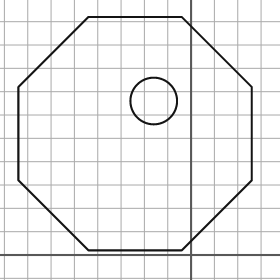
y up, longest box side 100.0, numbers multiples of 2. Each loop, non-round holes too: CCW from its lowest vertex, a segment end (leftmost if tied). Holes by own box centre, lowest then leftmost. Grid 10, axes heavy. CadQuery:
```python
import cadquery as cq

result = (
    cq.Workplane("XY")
    .moveTo(-44.0, 2.0)
    .lineTo(-4.0, 2.0)
    .lineTo(26.0, 32.0)
    .lineTo(26.0, 72.0)
    .lineTo(-4.0, 102.0)
    .lineTo(-44.0, 102.0)
    .lineTo(-74.0, 72.0)
    .lineTo(-74.0, 32.0)
    .close()
    .moveTo(-16.0, 66.0)
    .circle(10.0)
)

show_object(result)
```